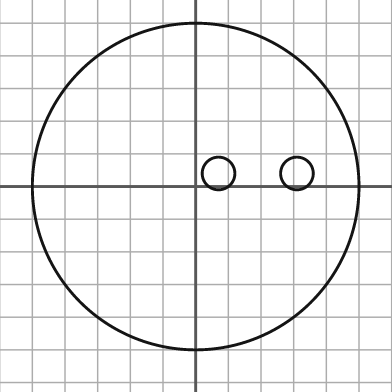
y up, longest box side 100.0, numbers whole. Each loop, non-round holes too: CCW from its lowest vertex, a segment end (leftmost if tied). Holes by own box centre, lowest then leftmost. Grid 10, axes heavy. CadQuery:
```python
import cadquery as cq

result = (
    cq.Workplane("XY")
    .moveTo(0.0, 0.0)
    .circle(50.0)
    .moveTo(7.0, 4.0)
    .circle(5.0)
    .moveTo(31.0, 4.0)
    .circle(5.0)
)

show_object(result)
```